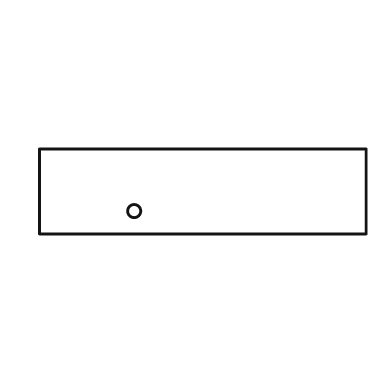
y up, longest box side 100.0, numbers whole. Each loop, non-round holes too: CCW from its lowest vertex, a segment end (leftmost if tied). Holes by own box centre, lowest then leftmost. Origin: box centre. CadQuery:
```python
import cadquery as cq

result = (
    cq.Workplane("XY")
    .moveTo(-50.0, -13.0)
    .lineTo(50.0, -13.0)
    .lineTo(50.0, 13.0)
    .lineTo(-50.0, 13.0)
    .close()
    .moveTo(-21.0, -6.0)
    .circle(2.0)
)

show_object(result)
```